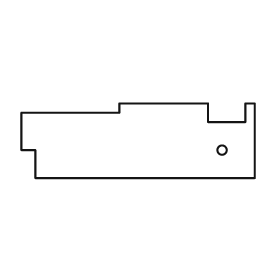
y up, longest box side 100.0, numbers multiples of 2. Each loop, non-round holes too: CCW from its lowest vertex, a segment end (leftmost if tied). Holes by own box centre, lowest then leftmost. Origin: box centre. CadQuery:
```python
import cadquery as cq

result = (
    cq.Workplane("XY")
    .moveTo(-44.0, -16.0)
    .lineTo(50.0, -16.0)
    .lineTo(50.0, 16.0)
    .lineTo(46.0, 16.0)
    .lineTo(46.0, 8.0)
    .lineTo(30.0, 8.0)
    .lineTo(30.0, 16.0)
    .lineTo(-8.0, 16.0)
    .lineTo(-8.0, 12.0)
    .lineTo(-50.0, 12.0)
    .lineTo(-50.0, -4.0)
    .lineTo(-44.0, -4.0)
    .close()
    .moveTo(36.0, -4.0)
    .circle(2.0)
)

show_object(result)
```